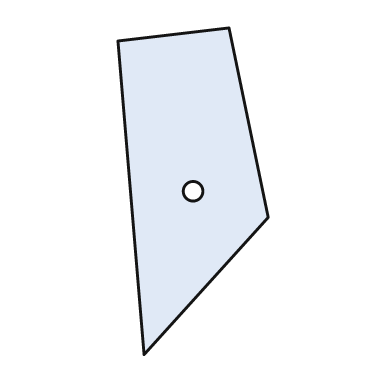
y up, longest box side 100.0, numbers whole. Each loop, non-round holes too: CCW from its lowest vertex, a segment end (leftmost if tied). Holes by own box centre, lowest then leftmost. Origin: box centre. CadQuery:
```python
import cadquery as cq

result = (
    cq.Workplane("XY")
    .moveTo(-15.0, -50.0)
    .lineTo(23.0, -8.0)
    .lineTo(11.0, 50.0)
    .lineTo(-23.0, 46.0)
    .close()
    .moveTo(0.0, 0.0)
    .circle(3.0)
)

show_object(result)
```